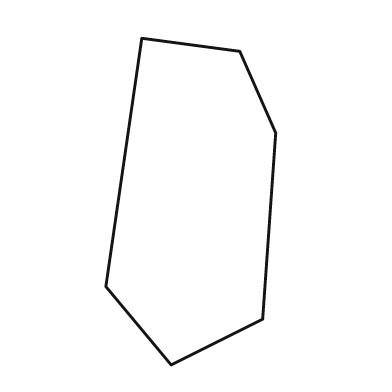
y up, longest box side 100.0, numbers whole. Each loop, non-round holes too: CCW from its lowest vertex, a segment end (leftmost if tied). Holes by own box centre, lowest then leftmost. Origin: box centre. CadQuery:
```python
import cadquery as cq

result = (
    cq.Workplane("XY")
    .moveTo(-6.0, -50.0)
    .lineTo(22.0, -36.0)
    .lineTo(26.0, 21.0)
    .lineTo(15.0, 46.0)
    .lineTo(-15.0, 50.0)
    .lineTo(-26.0, -26.0)
    .close()
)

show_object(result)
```